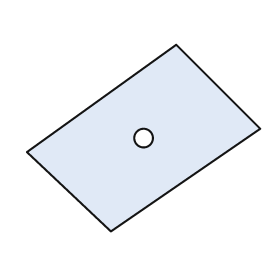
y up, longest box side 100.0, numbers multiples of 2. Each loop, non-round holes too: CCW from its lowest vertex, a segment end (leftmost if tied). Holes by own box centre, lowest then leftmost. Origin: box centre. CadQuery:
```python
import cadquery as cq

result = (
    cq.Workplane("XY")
    .moveTo(-14.0, -40.0)
    .lineTo(50.0, 4.0)
    .lineTo(14.0, 40.0)
    .lineTo(-50.0, -6.0)
    .close()
    .moveTo(0.0, 0.0)
    .circle(4.0)
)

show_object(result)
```